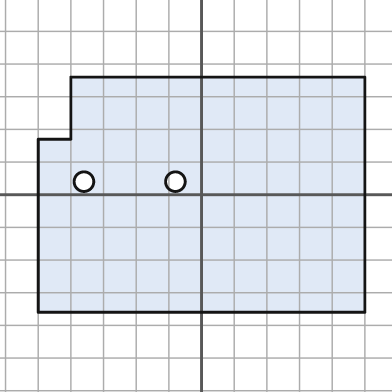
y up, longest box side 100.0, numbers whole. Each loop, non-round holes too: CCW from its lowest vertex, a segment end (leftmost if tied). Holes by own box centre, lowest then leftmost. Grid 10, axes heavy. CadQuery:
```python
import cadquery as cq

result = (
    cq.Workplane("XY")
    .moveTo(-50.0, -36.0)
    .lineTo(50.0, -36.0)
    .lineTo(50.0, 36.0)
    .lineTo(-40.0, 36.0)
    .lineTo(-40.0, 17.0)
    .lineTo(-50.0, 17.0)
    .close()
    .moveTo(-36.0, 4.0)
    .circle(3.0)
    .moveTo(-8.0, 4.0)
    .circle(3.0)
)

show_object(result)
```